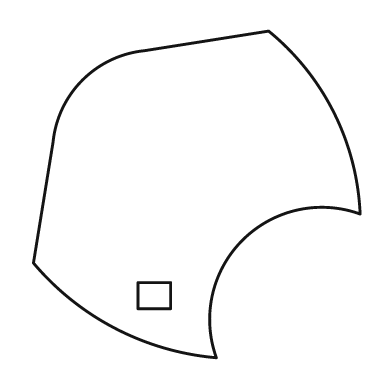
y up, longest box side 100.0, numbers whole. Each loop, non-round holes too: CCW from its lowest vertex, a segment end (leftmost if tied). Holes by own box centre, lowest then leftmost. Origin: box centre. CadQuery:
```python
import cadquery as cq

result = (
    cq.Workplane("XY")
    .moveTo(6.0, -50.0)
    .threePointArc((14.0, -14.0), (50.0, -6.0))
    .threePointArc((42.0, 25.0), (22.0, 50.0))
    .lineTo(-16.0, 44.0)
    .threePointArc((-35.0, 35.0), (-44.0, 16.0))
    .lineTo(-50.0, -21.0)
    .threePointArc((-25.0, -41.0), (6.0, -50.0))
    .close()
    .moveTo(-18.0, -35.0)
    .lineTo(-8.0, -35.0)
    .lineTo(-8.0, -27.0)
    .lineTo(-18.0, -27.0)
    .close()
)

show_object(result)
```